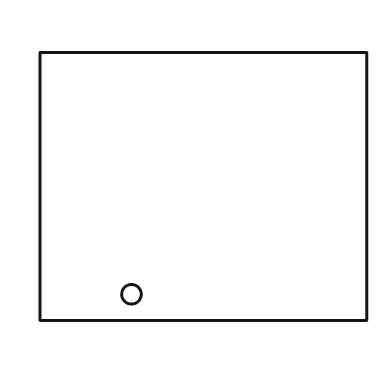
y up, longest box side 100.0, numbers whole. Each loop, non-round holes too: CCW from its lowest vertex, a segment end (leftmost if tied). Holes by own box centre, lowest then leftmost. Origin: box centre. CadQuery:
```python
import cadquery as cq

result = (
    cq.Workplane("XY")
    .moveTo(-50.0, -41.0)
    .lineTo(50.0, -41.0)
    .lineTo(50.0, 41.0)
    .lineTo(-50.0, 41.0)
    .close()
    .moveTo(-22.0, -33.0)
    .circle(3.0)
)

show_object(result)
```